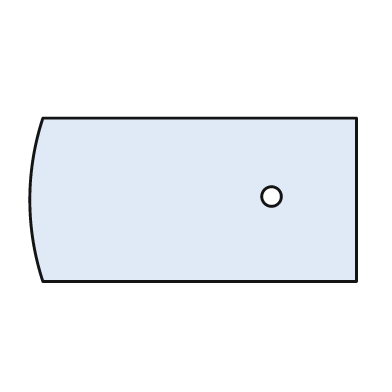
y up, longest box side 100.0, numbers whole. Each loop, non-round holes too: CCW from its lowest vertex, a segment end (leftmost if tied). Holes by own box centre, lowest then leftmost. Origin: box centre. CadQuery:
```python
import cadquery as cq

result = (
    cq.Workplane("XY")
    .moveTo(-46.0, -25.0)
    .lineTo(50.0, -25.0)
    .lineTo(50.0, 25.0)
    .lineTo(-46.0, 25.0)
    .threePointArc((-50.0, 0.0), (-46.0, -25.0))
    .close()
    .moveTo(24.0, 1.0)
    .circle(3.0)
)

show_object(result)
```